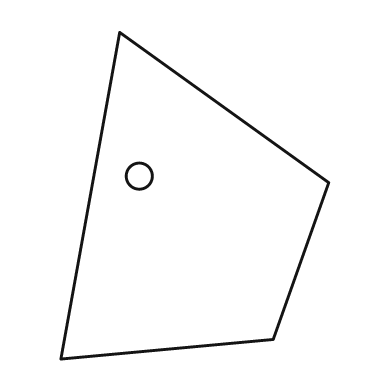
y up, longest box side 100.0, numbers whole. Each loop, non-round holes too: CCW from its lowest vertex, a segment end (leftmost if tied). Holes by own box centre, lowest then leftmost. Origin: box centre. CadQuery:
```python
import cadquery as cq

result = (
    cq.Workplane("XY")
    .moveTo(-41.0, -50.0)
    .lineTo(24.0, -44.0)
    .lineTo(41.0, 4.0)
    .lineTo(-23.0, 50.0)
    .close()
    .moveTo(-17.0, 6.0)
    .circle(4.0)
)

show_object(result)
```